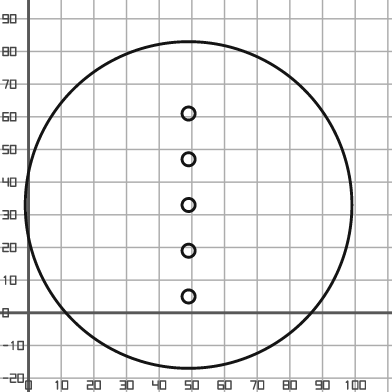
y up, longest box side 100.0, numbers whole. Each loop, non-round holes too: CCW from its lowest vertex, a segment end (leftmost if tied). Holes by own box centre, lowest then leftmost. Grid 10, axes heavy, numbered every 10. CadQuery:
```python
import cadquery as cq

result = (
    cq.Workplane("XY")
    .moveTo(49.0, 33.0)
    .circle(50.0)
    .moveTo(49.0, 5.0)
    .circle(2.0)
    .moveTo(49.0, 19.0)
    .circle(2.0)
    .moveTo(49.0, 33.0)
    .circle(2.0)
    .moveTo(49.0, 47.0)
    .circle(2.0)
    .moveTo(49.0, 61.0)
    .circle(2.0)
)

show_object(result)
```